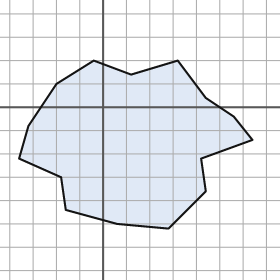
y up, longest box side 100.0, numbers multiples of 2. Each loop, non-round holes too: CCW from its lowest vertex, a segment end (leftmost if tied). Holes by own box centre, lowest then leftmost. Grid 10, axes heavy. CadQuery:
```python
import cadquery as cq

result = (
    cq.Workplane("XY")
    .moveTo(28.0, -52.0)
    .lineTo(44.0, -36.0)
    .lineTo(42.0, -22.0)
    .lineTo(64.0, -14.0)
    .lineTo(56.0, -4.0)
    .lineTo(44.0, 4.0)
    .lineTo(32.0, 20.0)
    .lineTo(12.0, 14.0)
    .lineTo(-4.0, 20.0)
    .lineTo(-20.0, 10.0)
    .lineTo(-32.0, -8.0)
    .lineTo(-36.0, -22.0)
    .lineTo(-18.0, -30.0)
    .lineTo(-16.0, -44.0)
    .lineTo(6.0, -50.0)
    .close()
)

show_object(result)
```